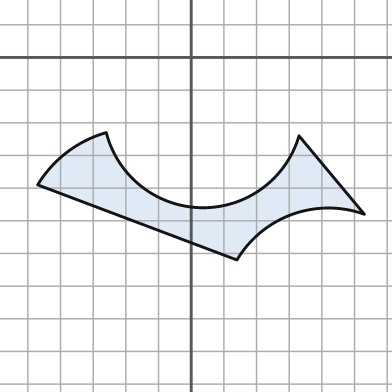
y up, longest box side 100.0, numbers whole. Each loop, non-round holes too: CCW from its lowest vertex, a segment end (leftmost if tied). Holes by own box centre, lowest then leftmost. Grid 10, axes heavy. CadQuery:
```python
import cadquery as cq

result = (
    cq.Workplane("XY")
    .moveTo(14.0, -62.0)
    .threePointArc((31.0, -48.0), (53.0, -48.0))
    .lineTo(33.0, -24.0)
    .threePointArc((3.0, -46.0), (-26.0, -23.0))
    .threePointArc((-38.0, -29.0), (-47.0, -39.0))
    .close()
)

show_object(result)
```